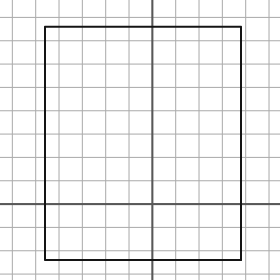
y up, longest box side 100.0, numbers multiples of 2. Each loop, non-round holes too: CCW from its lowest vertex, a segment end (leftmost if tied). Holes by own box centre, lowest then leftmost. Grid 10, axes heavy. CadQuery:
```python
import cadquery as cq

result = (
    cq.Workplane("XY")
    .moveTo(-46.0, -24.0)
    .lineTo(38.0, -24.0)
    .lineTo(38.0, 76.0)
    .lineTo(-46.0, 76.0)
    .close()
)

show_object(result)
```